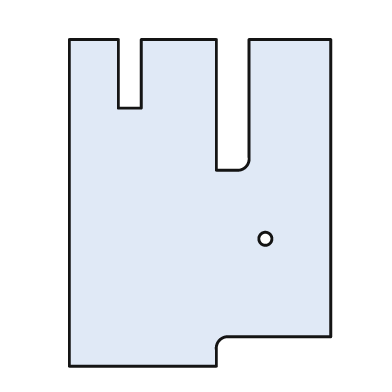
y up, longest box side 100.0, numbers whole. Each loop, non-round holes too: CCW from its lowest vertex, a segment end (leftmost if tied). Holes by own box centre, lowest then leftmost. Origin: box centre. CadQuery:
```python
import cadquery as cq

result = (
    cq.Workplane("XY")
    .moveTo(-40.0, -50.0)
    .lineTo(5.0, -50.0)
    .lineTo(5.0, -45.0)
    .threePointArc((6.0, -42.0), (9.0, -41.0))
    .lineTo(40.0, -41.0)
    .lineTo(40.0, 50.0)
    .lineTo(15.0, 50.0)
    .lineTo(15.0, 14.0)
    .threePointArc((14.0, 11.0), (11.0, 10.0))
    .lineTo(5.0, 10.0)
    .lineTo(5.0, 50.0)
    .lineTo(-18.0, 50.0)
    .lineTo(-18.0, 29.0)
    .lineTo(-25.0, 29.0)
    .lineTo(-25.0, 50.0)
    .lineTo(-40.0, 50.0)
    .close()
    .moveTo(20.0, -11.0)
    .circle(2.0)
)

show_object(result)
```